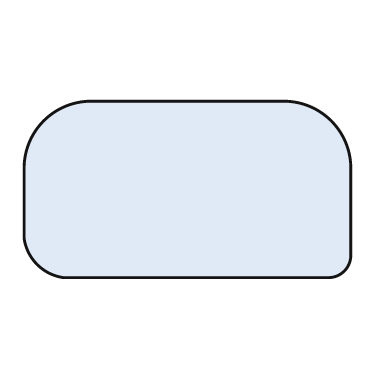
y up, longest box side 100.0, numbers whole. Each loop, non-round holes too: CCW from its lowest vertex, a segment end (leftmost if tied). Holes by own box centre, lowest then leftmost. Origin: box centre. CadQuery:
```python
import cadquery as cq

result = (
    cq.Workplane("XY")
    .moveTo(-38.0, -27.0)
    .lineTo(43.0, -27.0)
    .threePointArc((48.0, -25.0), (50.0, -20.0))
    .lineTo(50.0, 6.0)
    .threePointArc((44.0, 21.0), (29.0, 27.0))
    .lineTo(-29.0, 27.0)
    .threePointArc((-44.0, 21.0), (-50.0, 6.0))
    .lineTo(-50.0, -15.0)
    .threePointArc((-46.0, -23.0), (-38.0, -27.0))
    .close()
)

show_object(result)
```